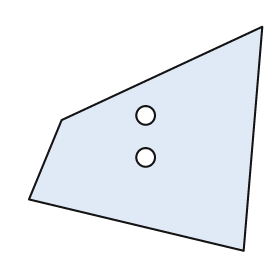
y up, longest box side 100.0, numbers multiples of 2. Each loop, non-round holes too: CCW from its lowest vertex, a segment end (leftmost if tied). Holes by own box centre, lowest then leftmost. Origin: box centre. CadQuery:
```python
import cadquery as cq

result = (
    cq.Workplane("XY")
    .moveTo(42.0, -48.0)
    .lineTo(50.0, 48.0)
    .lineTo(-36.0, 8.0)
    .lineTo(-50.0, -26.0)
    .close()
    .moveTo(0.0, -8.0)
    .circle(4.0)
    .moveTo(0.0, 10.0)
    .circle(4.0)
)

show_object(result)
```